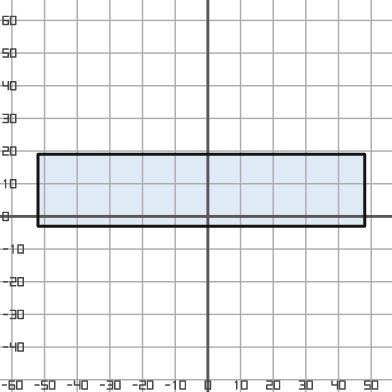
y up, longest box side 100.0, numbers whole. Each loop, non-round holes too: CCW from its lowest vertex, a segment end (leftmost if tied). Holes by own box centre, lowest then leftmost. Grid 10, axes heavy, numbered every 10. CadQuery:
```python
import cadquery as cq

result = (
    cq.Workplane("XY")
    .moveTo(-52.0, -3.0)
    .lineTo(48.0, -3.0)
    .lineTo(48.0, 19.0)
    .lineTo(-52.0, 19.0)
    .close()
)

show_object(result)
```